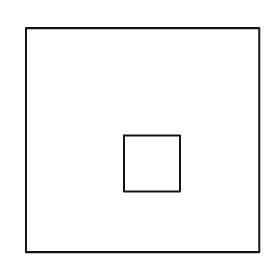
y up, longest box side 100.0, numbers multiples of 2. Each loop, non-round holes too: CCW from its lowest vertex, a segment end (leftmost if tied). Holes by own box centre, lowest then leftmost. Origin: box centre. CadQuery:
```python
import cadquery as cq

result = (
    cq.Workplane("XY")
    .moveTo(-50.0, -48.0)
    .lineTo(50.0, -48.0)
    .lineTo(50.0, 48.0)
    .lineTo(-50.0, 48.0)
    .close()
    .moveTo(-8.0, -22.0)
    .lineTo(16.0, -22.0)
    .lineTo(16.0, 2.0)
    .lineTo(-8.0, 2.0)
    .close()
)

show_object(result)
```